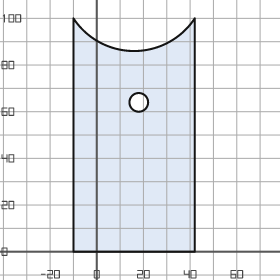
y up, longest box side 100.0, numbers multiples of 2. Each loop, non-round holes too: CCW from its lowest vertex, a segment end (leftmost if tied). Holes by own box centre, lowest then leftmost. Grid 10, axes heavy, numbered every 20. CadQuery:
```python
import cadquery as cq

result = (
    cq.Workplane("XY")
    .moveTo(-10.0, 0.0)
    .lineTo(42.0, 0.0)
    .lineTo(42.0, 100.0)
    .threePointArc((16.0, 86.0), (-10.0, 100.0))
    .close()
    .moveTo(18.0, 64.0)
    .circle(4.0)
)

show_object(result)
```